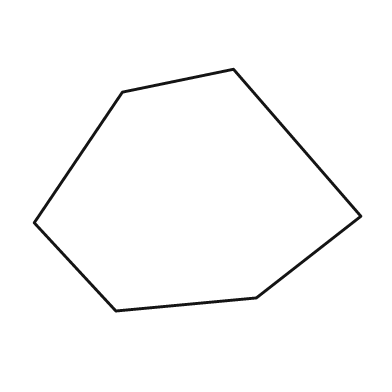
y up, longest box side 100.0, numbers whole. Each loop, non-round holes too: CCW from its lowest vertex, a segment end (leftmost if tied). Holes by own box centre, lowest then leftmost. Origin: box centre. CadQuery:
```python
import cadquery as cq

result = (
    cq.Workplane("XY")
    .moveTo(-25.0, -37.0)
    .lineTo(18.0, -33.0)
    .lineTo(50.0, -8.0)
    .lineTo(11.0, 37.0)
    .lineTo(-23.0, 30.0)
    .lineTo(-50.0, -10.0)
    .close()
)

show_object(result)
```